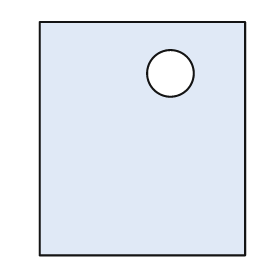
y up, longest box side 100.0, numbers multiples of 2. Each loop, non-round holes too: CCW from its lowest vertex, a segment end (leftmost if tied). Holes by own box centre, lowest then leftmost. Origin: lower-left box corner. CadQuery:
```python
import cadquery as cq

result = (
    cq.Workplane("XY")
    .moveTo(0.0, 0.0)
    .lineTo(88.0, 0.0)
    .lineTo(88.0, 100.0)
    .lineTo(0.0, 100.0)
    .close()
    .moveTo(56.0, 78.0)
    .circle(10.0)
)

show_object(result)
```